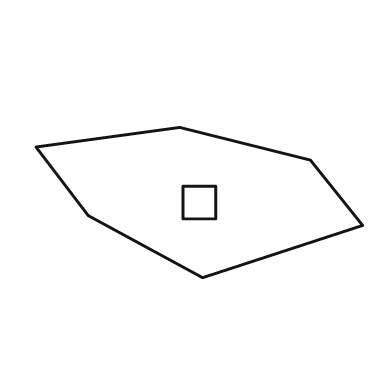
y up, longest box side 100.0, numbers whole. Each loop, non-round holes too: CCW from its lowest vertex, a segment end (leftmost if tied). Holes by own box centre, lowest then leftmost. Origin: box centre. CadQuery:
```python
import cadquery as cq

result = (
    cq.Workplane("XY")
    .moveTo(1.0, -23.0)
    .lineTo(50.0, -7.0)
    .lineTo(34.0, 13.0)
    .lineTo(-6.0, 23.0)
    .lineTo(-50.0, 17.0)
    .lineTo(-34.0, -4.0)
    .close()
    .moveTo(-5.0, -5.0)
    .lineTo(5.0, -5.0)
    .lineTo(5.0, 5.0)
    .lineTo(-5.0, 5.0)
    .close()
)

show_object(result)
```